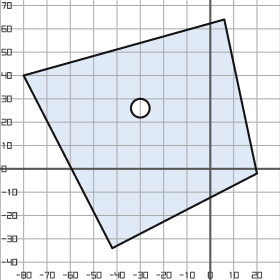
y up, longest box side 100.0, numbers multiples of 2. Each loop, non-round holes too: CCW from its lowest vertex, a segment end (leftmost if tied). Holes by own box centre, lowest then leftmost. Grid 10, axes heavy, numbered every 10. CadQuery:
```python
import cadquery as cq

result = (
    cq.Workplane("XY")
    .moveTo(-42.0, -34.0)
    .lineTo(20.0, -2.0)
    .lineTo(6.0, 64.0)
    .lineTo(-80.0, 40.0)
    .close()
    .moveTo(-30.0, 26.0)
    .circle(4.0)
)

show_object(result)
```